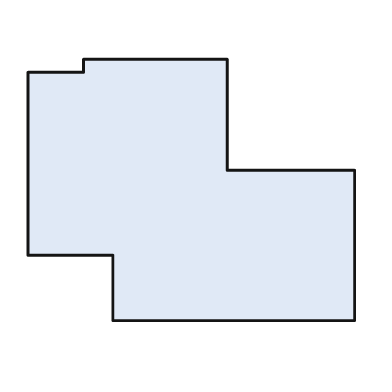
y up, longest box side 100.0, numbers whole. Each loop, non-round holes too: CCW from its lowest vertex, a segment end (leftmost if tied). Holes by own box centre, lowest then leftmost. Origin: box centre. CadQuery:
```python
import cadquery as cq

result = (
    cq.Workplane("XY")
    .moveTo(-24.0, -40.0)
    .lineTo(50.0, -40.0)
    .lineTo(50.0, 6.0)
    .lineTo(11.0, 6.0)
    .lineTo(11.0, 40.0)
    .lineTo(-33.0, 40.0)
    .lineTo(-33.0, 36.0)
    .lineTo(-50.0, 36.0)
    .lineTo(-50.0, -20.0)
    .lineTo(-24.0, -20.0)
    .close()
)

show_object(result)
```